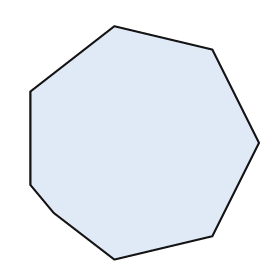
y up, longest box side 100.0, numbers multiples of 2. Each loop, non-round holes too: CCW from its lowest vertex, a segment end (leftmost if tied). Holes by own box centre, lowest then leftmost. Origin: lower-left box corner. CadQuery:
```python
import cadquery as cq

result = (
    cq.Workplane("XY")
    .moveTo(36.0, 0.0)
    .lineTo(78.0, 10.0)
    .lineTo(98.0, 50.0)
    .lineTo(78.0, 90.0)
    .lineTo(36.0, 100.0)
    .lineTo(0.0, 72.0)
    .lineTo(0.0, 32.0)
    .lineTo(10.0, 20.0)
    .close()
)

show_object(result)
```